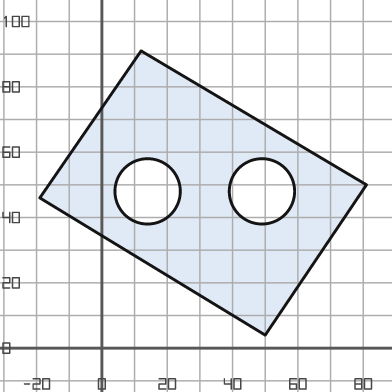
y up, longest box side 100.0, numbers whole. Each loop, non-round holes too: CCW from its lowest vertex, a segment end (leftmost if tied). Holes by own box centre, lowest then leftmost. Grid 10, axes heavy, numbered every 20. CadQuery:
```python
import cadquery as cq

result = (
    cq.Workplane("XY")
    .moveTo(50.0, 4.0)
    .lineTo(81.0, 50.0)
    .lineTo(12.0, 91.0)
    .lineTo(-19.0, 46.0)
    .close()
    .moveTo(14.0, 48.0)
    .circle(10.0)
    .moveTo(49.0, 48.0)
    .circle(10.0)
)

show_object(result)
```